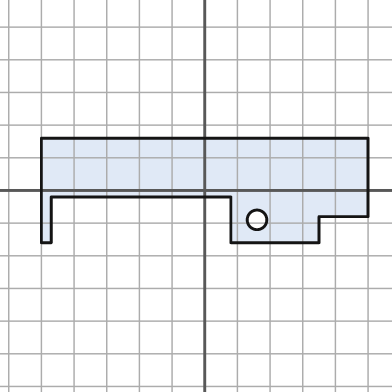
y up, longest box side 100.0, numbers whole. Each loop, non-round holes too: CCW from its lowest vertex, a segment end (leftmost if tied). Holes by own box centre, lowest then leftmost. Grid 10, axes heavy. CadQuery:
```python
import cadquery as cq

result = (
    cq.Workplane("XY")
    .moveTo(-50.0, -16.0)
    .lineTo(-47.0, -16.0)
    .lineTo(-47.0, -2.0)
    .lineTo(8.0, -2.0)
    .lineTo(8.0, -16.0)
    .lineTo(35.0, -16.0)
    .lineTo(35.0, -8.0)
    .lineTo(50.0, -8.0)
    .lineTo(50.0, 16.0)
    .lineTo(-50.0, 16.0)
    .close()
    .moveTo(16.0, -9.0)
    .circle(3.0)
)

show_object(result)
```